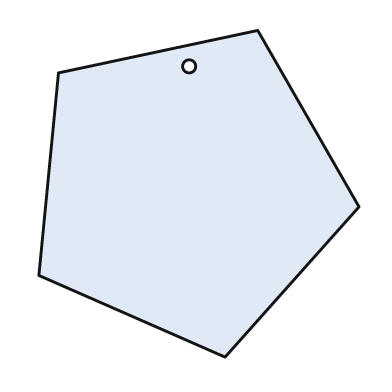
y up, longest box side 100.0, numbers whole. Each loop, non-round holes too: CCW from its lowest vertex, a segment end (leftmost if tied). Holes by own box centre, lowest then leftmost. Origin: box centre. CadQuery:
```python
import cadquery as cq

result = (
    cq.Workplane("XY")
    .moveTo(8.0, -50.0)
    .lineTo(49.0, -4.0)
    .lineTo(18.0, 50.0)
    .lineTo(-43.0, 37.0)
    .lineTo(-49.0, -25.0)
    .close()
    .moveTo(-3.0, 39.0)
    .circle(2.0)
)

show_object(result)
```